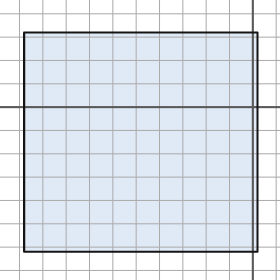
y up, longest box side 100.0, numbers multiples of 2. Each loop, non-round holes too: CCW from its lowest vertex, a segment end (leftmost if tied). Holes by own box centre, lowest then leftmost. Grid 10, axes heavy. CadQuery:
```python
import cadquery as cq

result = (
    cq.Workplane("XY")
    .moveTo(-98.0, -62.0)
    .lineTo(2.0, -62.0)
    .lineTo(2.0, 32.0)
    .lineTo(-98.0, 32.0)
    .close()
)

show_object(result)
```